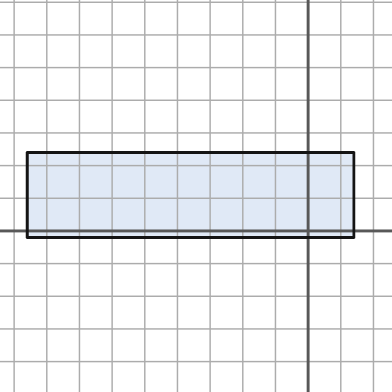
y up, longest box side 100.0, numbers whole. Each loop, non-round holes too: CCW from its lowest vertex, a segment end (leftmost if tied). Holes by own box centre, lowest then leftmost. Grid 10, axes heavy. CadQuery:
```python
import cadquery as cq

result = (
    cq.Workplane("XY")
    .moveTo(-86.0, -2.0)
    .lineTo(14.0, -2.0)
    .lineTo(14.0, 24.0)
    .lineTo(-86.0, 24.0)
    .close()
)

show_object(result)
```